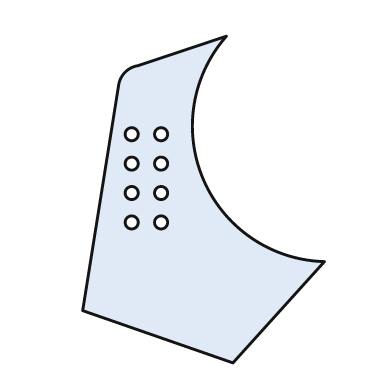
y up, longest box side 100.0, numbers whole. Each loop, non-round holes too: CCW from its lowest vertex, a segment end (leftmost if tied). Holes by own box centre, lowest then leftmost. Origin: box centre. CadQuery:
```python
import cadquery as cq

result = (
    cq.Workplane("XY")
    .moveTo(9.0, -50.0)
    .lineTo(37.0, -19.0)
    .threePointArc((0.0, 6.0), (7.0, 50.0))
    .lineTo(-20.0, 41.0)
    .threePointArc((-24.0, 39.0), (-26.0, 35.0))
    .lineTo(-37.0, -34.0)
    .close()
    .moveTo(-22.0, -7.0)
    .circle(2.0)
    .moveTo(-13.0, -7.0)
    .circle(2.0)
    .moveTo(-22.0, 2.0)
    .circle(2.0)
    .moveTo(-13.0, 2.0)
    .circle(2.0)
    .moveTo(-22.0, 11.0)
    .circle(2.0)
    .moveTo(-13.0, 11.0)
    .circle(2.0)
    .moveTo(-22.0, 20.0)
    .circle(2.0)
    .moveTo(-13.0, 20.0)
    .circle(2.0)
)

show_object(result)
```